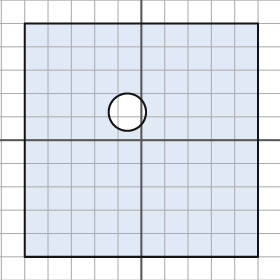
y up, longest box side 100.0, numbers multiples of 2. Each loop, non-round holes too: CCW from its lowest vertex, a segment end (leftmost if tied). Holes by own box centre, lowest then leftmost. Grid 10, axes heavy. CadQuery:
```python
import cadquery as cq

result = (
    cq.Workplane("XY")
    .moveTo(-50.0, -50.0)
    .lineTo(50.0, -50.0)
    .lineTo(50.0, 50.0)
    .lineTo(-50.0, 50.0)
    .close()
    .moveTo(-6.0, 12.0)
    .circle(8.0)
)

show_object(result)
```